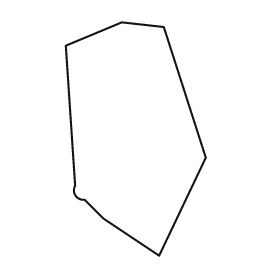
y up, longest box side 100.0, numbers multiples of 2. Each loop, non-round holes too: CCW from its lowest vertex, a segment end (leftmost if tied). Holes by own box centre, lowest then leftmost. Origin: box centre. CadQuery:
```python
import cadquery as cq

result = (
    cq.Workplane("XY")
    .moveTo(10.0, -50.0)
    .lineTo(30.0, -8.0)
    .lineTo(12.0, 48.0)
    .lineTo(-6.0, 50.0)
    .lineTo(-30.0, 40.0)
    .lineTo(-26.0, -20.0)
    .threePointArc((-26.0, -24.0), (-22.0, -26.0))
    .lineTo(-14.0, -34.0)
    .close()
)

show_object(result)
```